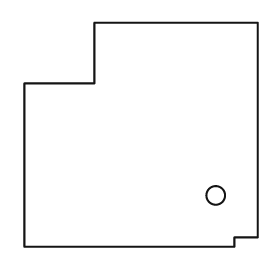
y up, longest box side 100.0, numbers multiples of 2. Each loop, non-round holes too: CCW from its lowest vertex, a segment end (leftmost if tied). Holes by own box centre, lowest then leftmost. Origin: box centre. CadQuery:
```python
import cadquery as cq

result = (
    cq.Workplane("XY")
    .moveTo(-50.0, -48.0)
    .lineTo(40.0, -48.0)
    .lineTo(40.0, -44.0)
    .lineTo(50.0, -44.0)
    .lineTo(50.0, 48.0)
    .lineTo(-20.0, 48.0)
    .lineTo(-20.0, 22.0)
    .lineTo(-50.0, 22.0)
    .close()
    .moveTo(32.0, -26.0)
    .circle(4.0)
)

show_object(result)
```